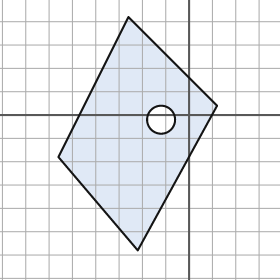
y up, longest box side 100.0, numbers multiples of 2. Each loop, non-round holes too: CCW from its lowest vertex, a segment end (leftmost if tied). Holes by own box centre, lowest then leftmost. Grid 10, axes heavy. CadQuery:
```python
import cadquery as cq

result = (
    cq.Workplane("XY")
    .moveTo(-22.0, -58.0)
    .lineTo(12.0, 4.0)
    .lineTo(-26.0, 42.0)
    .lineTo(-56.0, -18.0)
    .close()
    .moveTo(-12.0, -2.0)
    .circle(6.0)
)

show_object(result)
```